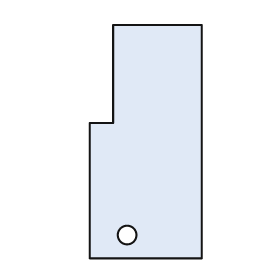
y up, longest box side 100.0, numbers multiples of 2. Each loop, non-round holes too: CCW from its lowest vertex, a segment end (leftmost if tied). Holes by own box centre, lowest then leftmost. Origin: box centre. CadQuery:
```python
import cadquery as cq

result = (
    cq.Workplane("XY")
    .moveTo(-24.0, -50.0)
    .lineTo(24.0, -50.0)
    .lineTo(24.0, 50.0)
    .lineTo(-14.0, 50.0)
    .lineTo(-14.0, 8.0)
    .lineTo(-24.0, 8.0)
    .close()
    .moveTo(-8.0, -40.0)
    .circle(4.0)
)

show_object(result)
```